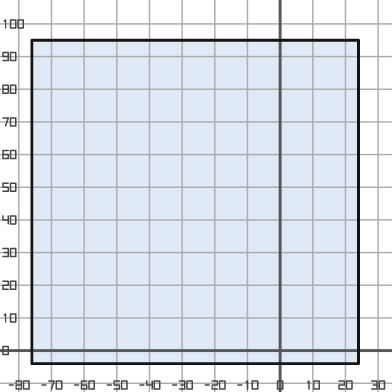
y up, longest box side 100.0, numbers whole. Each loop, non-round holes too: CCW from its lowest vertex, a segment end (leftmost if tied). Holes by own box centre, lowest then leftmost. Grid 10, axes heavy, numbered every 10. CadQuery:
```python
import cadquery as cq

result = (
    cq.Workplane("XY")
    .moveTo(-76.0, -4.0)
    .lineTo(24.0, -4.0)
    .lineTo(24.0, 95.0)
    .lineTo(-76.0, 95.0)
    .close()
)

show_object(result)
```